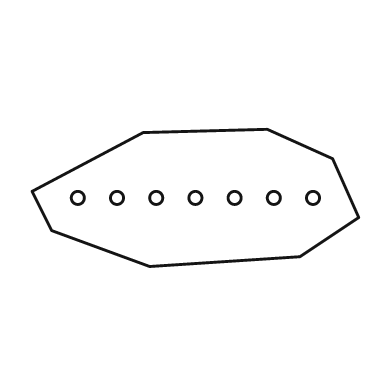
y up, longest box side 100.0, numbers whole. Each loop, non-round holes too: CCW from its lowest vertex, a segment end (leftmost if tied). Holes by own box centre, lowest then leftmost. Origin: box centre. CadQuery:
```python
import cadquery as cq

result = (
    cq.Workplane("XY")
    .moveTo(-14.0, -21.0)
    .lineTo(32.0, -18.0)
    .lineTo(50.0, -6.0)
    .lineTo(42.0, 12.0)
    .lineTo(22.0, 21.0)
    .lineTo(-16.0, 20.0)
    .lineTo(-50.0, 2.0)
    .lineTo(-44.0, -10.0)
    .close()
    .moveTo(-36.0, 0.0)
    .circle(2.0)
    .moveTo(-24.0, 0.0)
    .circle(2.0)
    .moveTo(-12.0, 0.0)
    .circle(2.0)
    .moveTo(0.0, 0.0)
    .circle(2.0)
    .moveTo(12.0, 0.0)
    .circle(2.0)
    .moveTo(24.0, 0.0)
    .circle(2.0)
    .moveTo(36.0, 0.0)
    .circle(2.0)
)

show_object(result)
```